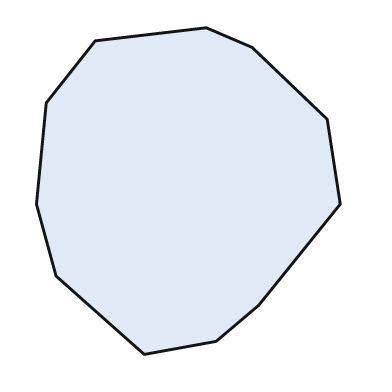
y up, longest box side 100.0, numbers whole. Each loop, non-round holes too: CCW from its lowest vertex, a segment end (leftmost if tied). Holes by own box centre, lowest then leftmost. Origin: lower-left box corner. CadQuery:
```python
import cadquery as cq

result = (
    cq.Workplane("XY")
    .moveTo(33.0, 0.0)
    .lineTo(55.0, 4.0)
    .lineTo(68.0, 15.0)
    .lineTo(93.0, 46.0)
    .lineTo(89.0, 72.0)
    .lineTo(66.0, 94.0)
    .lineTo(52.0, 100.0)
    .lineTo(18.0, 96.0)
    .lineTo(3.0, 77.0)
    .lineTo(0.0, 46.0)
    .lineTo(6.0, 24.0)
    .close()
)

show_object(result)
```